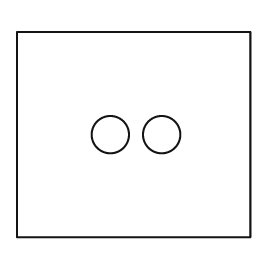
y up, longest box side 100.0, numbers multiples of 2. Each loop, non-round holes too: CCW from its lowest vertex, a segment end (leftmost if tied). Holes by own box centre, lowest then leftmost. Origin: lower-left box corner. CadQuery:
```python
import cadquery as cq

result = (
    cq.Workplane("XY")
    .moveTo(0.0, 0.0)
    .lineTo(100.0, 0.0)
    .lineTo(100.0, 88.0)
    .lineTo(0.0, 88.0)
    .close()
    .moveTo(40.0, 44.0)
    .circle(8.0)
    .moveTo(62.0, 44.0)
    .circle(8.0)
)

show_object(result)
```